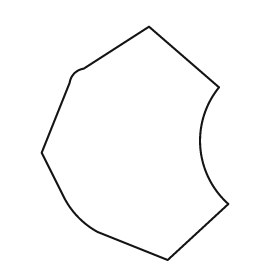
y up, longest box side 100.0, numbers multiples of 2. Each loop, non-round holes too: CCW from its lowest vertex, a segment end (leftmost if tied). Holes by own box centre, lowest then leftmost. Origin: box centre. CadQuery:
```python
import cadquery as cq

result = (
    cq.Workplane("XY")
    .moveTo(14.0, -50.0)
    .lineTo(40.0, -26.0)
    .threePointArc((28.0, -2.0), (36.0, 24.0))
    .lineTo(6.0, 50.0)
    .lineTo(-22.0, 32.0)
    .threePointArc((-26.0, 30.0), (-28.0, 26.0))
    .lineTo(-40.0, -4.0)
    .lineTo(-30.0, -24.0)
    .threePointArc((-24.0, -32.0), (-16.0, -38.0))
    .close()
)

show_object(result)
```